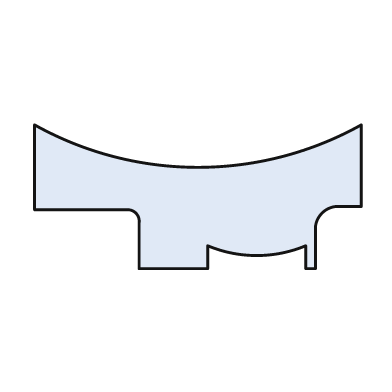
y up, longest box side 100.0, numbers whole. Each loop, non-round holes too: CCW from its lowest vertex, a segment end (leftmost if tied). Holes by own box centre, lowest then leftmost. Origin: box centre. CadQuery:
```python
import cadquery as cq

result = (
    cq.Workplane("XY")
    .moveTo(-18.0, -22.0)
    .lineTo(3.0, -22.0)
    .lineTo(3.0, -15.0)
    .threePointArc((18.0, -18.0), (33.0, -15.0))
    .lineTo(33.0, -22.0)
    .lineTo(36.0, -22.0)
    .lineTo(36.0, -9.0)
    .threePointArc((38.0, -5.0), (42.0, -3.0))
    .lineTo(50.0, -3.0)
    .lineTo(50.0, 22.0)
    .threePointArc((0.0, 9.0), (-50.0, 22.0))
    .lineTo(-50.0, -4.0)
    .lineTo(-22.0, -4.0)
    .threePointArc((-19.0, -5.0), (-18.0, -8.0))
    .close()
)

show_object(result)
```